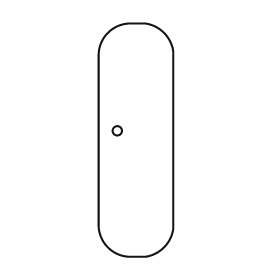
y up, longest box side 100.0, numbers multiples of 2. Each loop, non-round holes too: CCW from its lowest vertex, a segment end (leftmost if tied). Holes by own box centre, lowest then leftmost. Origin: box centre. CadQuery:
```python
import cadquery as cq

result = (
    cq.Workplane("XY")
    .moveTo(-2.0, -50.0)
    .lineTo(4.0, -50.0)
    .threePointArc((12.0, -46.0), (16.0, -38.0))
    .lineTo(16.0, 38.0)
    .threePointArc((12.0, 46.0), (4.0, 50.0))
    .lineTo(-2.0, 50.0)
    .threePointArc((-12.0, 46.0), (-16.0, 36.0))
    .lineTo(-16.0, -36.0)
    .threePointArc((-12.0, -46.0), (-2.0, -50.0))
    .close()
    .moveTo(-8.0, 4.0)
    .circle(2.0)
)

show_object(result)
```